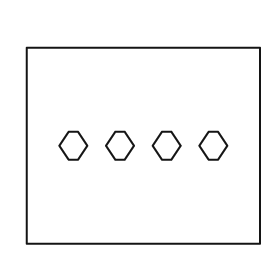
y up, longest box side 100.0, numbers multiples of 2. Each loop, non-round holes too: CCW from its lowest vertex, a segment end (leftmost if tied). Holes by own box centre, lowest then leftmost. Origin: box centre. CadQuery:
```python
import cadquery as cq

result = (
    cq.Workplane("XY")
    .moveTo(-50.0, -42.0)
    .lineTo(50.0, -42.0)
    .lineTo(50.0, 42.0)
    .lineTo(-50.0, 42.0)
    .close()
    .moveTo(-32.0, -6.0)
    .lineTo(-28.0, -6.0)
    .lineTo(-24.0, 0.0)
    .lineTo(-28.0, 6.0)
    .lineTo(-32.0, 6.0)
    .lineTo(-36.0, 0.0)
    .close()
    .moveTo(-12.0, -6.0)
    .lineTo(-8.0, -6.0)
    .lineTo(-4.0, 0.0)
    .lineTo(-8.0, 6.0)
    .lineTo(-12.0, 6.0)
    .lineTo(-16.0, 0.0)
    .close()
    .moveTo(8.0, -6.0)
    .lineTo(12.0, -6.0)
    .lineTo(16.0, 0.0)
    .lineTo(12.0, 6.0)
    .lineTo(8.0, 6.0)
    .lineTo(4.0, 0.0)
    .close()
    .moveTo(28.0, -6.0)
    .lineTo(32.0, -6.0)
    .lineTo(36.0, 0.0)
    .lineTo(32.0, 6.0)
    .lineTo(28.0, 6.0)
    .lineTo(24.0, 0.0)
    .close()
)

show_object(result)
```